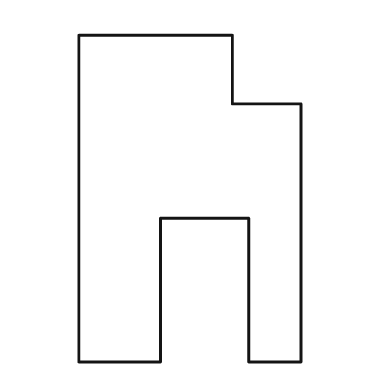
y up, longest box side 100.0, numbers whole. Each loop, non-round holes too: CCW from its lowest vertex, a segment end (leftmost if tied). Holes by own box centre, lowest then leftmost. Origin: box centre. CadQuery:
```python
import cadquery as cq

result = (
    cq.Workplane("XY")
    .moveTo(-34.0, -50.0)
    .lineTo(-9.0, -50.0)
    .lineTo(-9.0, -6.0)
    .lineTo(18.0, -6.0)
    .lineTo(18.0, -50.0)
    .lineTo(34.0, -50.0)
    .lineTo(34.0, 29.0)
    .lineTo(13.0, 29.0)
    .lineTo(13.0, 50.0)
    .lineTo(-34.0, 50.0)
    .close()
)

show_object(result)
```